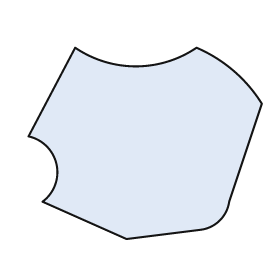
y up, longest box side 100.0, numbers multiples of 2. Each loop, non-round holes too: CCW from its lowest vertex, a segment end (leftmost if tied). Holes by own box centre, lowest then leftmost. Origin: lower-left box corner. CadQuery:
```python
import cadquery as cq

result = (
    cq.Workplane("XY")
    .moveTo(42.0, 0.0)
    .lineTo(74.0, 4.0)
    .threePointArc((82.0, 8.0), (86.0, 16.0))
    .lineTo(100.0, 58.0)
    .threePointArc((88.0, 72.0), (72.0, 82.0))
    .threePointArc((46.0, 74.0), (20.0, 82.0))
    .lineTo(0.0, 44.0)
    .threePointArc((12.0, 32.0), (6.0, 16.0))
    .close()
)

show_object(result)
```